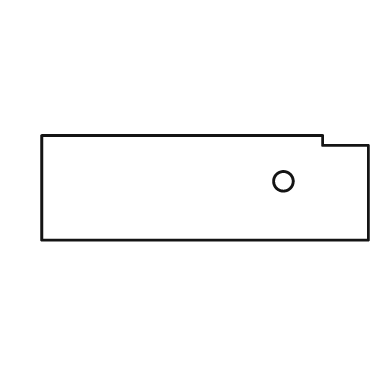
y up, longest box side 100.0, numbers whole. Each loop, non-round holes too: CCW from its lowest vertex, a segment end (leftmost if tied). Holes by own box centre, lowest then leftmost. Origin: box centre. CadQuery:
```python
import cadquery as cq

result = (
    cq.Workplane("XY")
    .moveTo(-50.0, -16.0)
    .lineTo(50.0, -16.0)
    .lineTo(50.0, 13.0)
    .lineTo(36.0, 13.0)
    .lineTo(36.0, 16.0)
    .lineTo(-50.0, 16.0)
    .close()
    .moveTo(24.0, 2.0)
    .circle(3.0)
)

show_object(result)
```